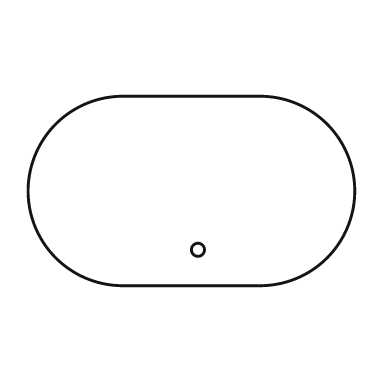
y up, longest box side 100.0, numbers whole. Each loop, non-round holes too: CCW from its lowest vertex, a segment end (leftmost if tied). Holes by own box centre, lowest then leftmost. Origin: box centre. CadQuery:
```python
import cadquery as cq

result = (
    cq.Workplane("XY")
    .moveTo(-21.0, -29.0)
    .lineTo(21.0, -29.0)
    .threePointArc((50.0, 0.0), (21.0, 29.0))
    .lineTo(-21.0, 29.0)
    .threePointArc((-50.0, 0.0), (-21.0, -29.0))
    .close()
    .moveTo(2.0, -18.0)
    .circle(2.0)
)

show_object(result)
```